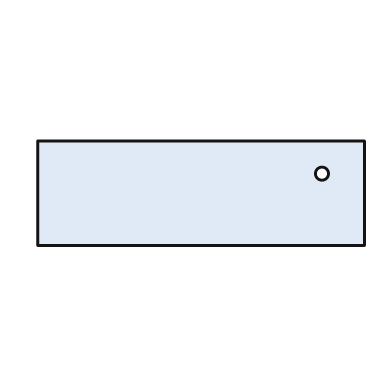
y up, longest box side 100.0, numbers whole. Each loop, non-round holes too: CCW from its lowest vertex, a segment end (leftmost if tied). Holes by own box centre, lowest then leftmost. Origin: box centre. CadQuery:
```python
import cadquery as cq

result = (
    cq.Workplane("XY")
    .moveTo(-50.0, -16.0)
    .lineTo(50.0, -16.0)
    .lineTo(50.0, 16.0)
    .lineTo(-50.0, 16.0)
    .close()
    .moveTo(37.0, 6.0)
    .circle(2.0)
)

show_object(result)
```